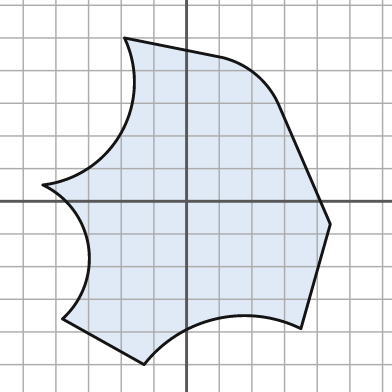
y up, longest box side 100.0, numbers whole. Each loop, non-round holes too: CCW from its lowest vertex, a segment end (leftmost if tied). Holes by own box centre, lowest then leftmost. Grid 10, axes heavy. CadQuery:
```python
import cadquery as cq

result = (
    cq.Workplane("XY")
    .moveTo(-13.0, -50.0)
    .threePointArc((9.0, -36.0), (35.0, -39.0))
    .lineTo(44.0, -7.0)
    .lineTo(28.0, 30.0)
    .threePointArc((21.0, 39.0), (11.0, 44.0))
    .lineTo(-19.0, 50.0)
    .threePointArc((-20.0, 21.0), (-44.0, 5.0))
    .threePointArc((-30.0, -14.0), (-38.0, -36.0))
    .close()
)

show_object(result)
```